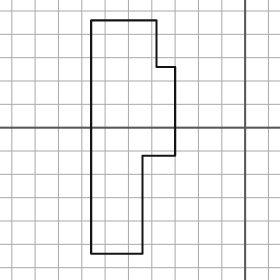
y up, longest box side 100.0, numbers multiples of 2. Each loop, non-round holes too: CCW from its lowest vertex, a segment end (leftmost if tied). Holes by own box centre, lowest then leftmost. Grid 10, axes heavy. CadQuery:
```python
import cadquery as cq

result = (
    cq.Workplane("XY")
    .moveTo(-66.0, -54.0)
    .lineTo(-44.0, -54.0)
    .lineTo(-44.0, -12.0)
    .lineTo(-30.0, -12.0)
    .lineTo(-30.0, 26.0)
    .lineTo(-38.0, 26.0)
    .lineTo(-38.0, 46.0)
    .lineTo(-66.0, 46.0)
    .close()
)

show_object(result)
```